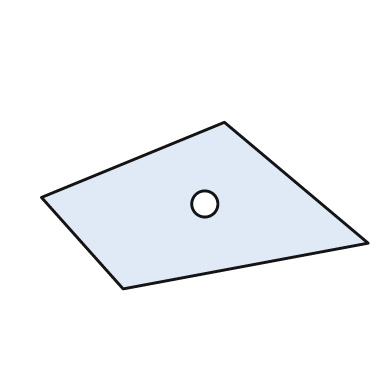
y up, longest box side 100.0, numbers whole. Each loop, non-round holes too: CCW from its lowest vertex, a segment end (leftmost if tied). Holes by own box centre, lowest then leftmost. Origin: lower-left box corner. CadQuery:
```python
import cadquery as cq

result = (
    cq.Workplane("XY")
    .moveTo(25.0, 0.0)
    .lineTo(100.0, 14.0)
    .lineTo(56.0, 51.0)
    .lineTo(0.0, 28.0)
    .close()
    .moveTo(50.0, 26.0)
    .circle(4.0)
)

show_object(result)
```